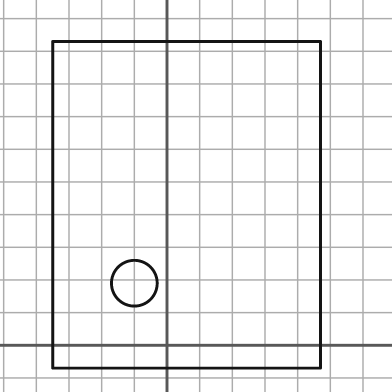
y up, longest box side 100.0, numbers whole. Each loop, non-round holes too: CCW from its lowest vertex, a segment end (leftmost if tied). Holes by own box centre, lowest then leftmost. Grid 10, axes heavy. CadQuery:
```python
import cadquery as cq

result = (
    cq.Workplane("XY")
    .moveTo(-35.0, -7.0)
    .lineTo(47.0, -7.0)
    .lineTo(47.0, 93.0)
    .lineTo(-35.0, 93.0)
    .close()
    .moveTo(-10.0, 19.0)
    .circle(7.0)
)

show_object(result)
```